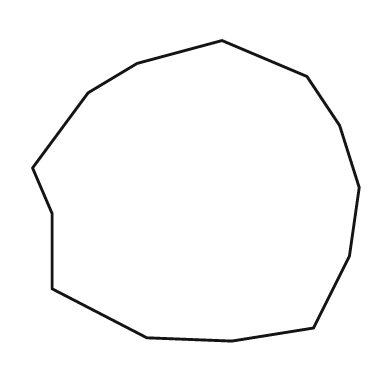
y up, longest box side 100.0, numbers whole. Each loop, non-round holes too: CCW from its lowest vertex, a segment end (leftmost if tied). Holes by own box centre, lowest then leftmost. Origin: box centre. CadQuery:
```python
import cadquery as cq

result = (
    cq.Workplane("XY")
    .moveTo(11.0, -46.0)
    .lineTo(36.0, -42.0)
    .lineTo(47.0, -20.0)
    .lineTo(50.0, 1.0)
    .lineTo(44.0, 20.0)
    .lineTo(34.0, 35.0)
    .lineTo(8.0, 46.0)
    .lineTo(-18.0, 39.0)
    .lineTo(-33.0, 30.0)
    .lineTo(-50.0, 7.0)
    .lineTo(-44.0, -7.0)
    .lineTo(-44.0, -30.0)
    .lineTo(-15.0, -45.0)
    .close()
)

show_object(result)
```